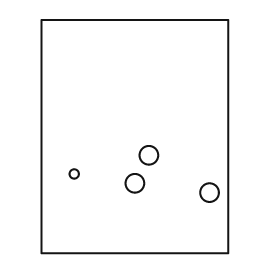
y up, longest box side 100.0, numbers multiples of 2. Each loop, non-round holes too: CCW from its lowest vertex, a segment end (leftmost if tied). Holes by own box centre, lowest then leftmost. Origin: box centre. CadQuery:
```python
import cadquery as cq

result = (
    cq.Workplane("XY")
    .moveTo(-40.0, -50.0)
    .lineTo(40.0, -50.0)
    .lineTo(40.0, 50.0)
    .lineTo(-40.0, 50.0)
    .close()
    .moveTo(32.0, -24.0)
    .circle(4.0)
    .moveTo(0.0, -20.0)
    .circle(4.0)
    .moveTo(-26.0, -16.0)
    .circle(2.0)
    .moveTo(6.0, -8.0)
    .circle(4.0)
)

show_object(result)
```